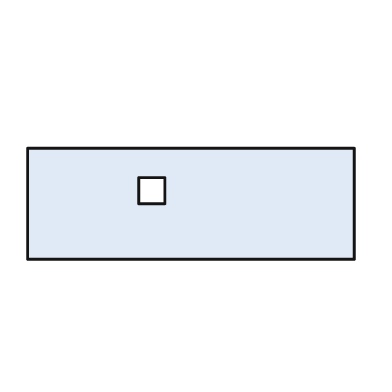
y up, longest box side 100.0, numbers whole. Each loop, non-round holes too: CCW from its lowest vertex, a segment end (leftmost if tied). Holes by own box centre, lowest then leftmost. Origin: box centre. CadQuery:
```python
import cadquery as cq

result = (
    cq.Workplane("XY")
    .moveTo(-50.0, -17.0)
    .lineTo(50.0, -17.0)
    .lineTo(50.0, 17.0)
    .lineTo(-50.0, 17.0)
    .close()
    .moveTo(-16.0, 0.0)
    .lineTo(-8.0, 0.0)
    .lineTo(-8.0, 8.0)
    .lineTo(-16.0, 8.0)
    .close()
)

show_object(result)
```